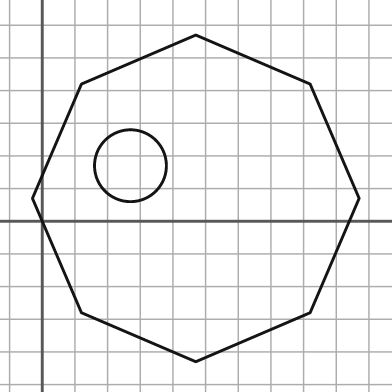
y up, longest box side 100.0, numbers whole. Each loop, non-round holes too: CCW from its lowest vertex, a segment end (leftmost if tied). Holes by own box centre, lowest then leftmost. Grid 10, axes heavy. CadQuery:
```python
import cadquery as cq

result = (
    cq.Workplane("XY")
    .moveTo(47.0, -43.0)
    .lineTo(82.0, -28.0)
    .lineTo(97.0, 7.0)
    .lineTo(82.0, 42.0)
    .lineTo(47.0, 57.0)
    .lineTo(12.0, 42.0)
    .lineTo(-3.0, 7.0)
    .lineTo(12.0, -28.0)
    .close()
    .moveTo(27.0, 17.0)
    .circle(11.0)
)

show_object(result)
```